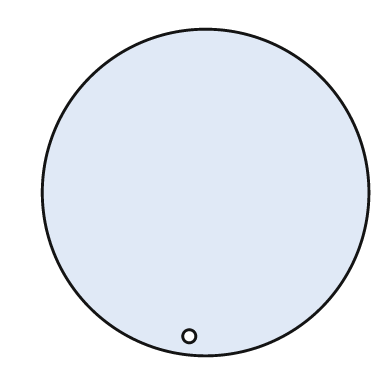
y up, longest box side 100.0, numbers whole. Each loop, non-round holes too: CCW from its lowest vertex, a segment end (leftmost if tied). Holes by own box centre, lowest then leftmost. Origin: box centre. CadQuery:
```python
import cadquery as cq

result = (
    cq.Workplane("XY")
    .moveTo(0.0, 0.0)
    .circle(50.0)
    .moveTo(-5.0, -44.0)
    .circle(2.0)
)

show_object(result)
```